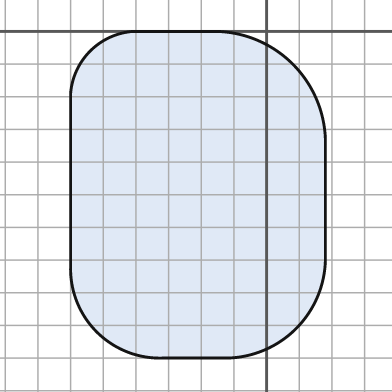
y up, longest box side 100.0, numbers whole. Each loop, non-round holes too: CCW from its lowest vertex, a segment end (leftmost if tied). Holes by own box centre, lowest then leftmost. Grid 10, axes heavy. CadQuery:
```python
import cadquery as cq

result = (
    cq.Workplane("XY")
    .moveTo(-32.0, -100.0)
    .lineTo(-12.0, -100.0)
    .threePointArc((9.0, -91.0), (18.0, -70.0))
    .lineTo(18.0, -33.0)
    .threePointArc((8.0, -10.0), (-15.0, 0.0))
    .lineTo(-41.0, 0.0)
    .threePointArc((-54.0, -6.0), (-60.0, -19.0))
    .lineTo(-60.0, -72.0)
    .threePointArc((-52.0, -92.0), (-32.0, -100.0))
    .close()
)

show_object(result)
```